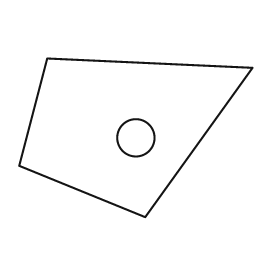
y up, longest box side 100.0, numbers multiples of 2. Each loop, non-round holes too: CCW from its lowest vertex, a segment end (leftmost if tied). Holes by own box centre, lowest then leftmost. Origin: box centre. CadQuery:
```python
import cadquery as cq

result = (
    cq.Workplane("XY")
    .moveTo(4.0, -34.0)
    .lineTo(50.0, 30.0)
    .lineTo(-38.0, 34.0)
    .lineTo(-50.0, -12.0)
    .close()
    .moveTo(0.0, 0.0)
    .circle(8.0)
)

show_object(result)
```